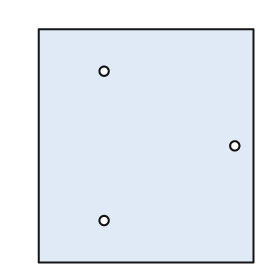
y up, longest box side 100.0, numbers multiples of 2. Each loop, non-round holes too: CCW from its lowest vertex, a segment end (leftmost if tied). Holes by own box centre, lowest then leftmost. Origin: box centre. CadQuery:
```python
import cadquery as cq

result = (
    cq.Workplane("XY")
    .moveTo(-46.0, -50.0)
    .lineTo(46.0, -50.0)
    .lineTo(46.0, 50.0)
    .lineTo(-46.0, 50.0)
    .close()
    .moveTo(-18.0, -32.0)
    .circle(2.0)
    .moveTo(38.0, 0.0)
    .circle(2.0)
    .moveTo(-18.0, 32.0)
    .circle(2.0)
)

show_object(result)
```